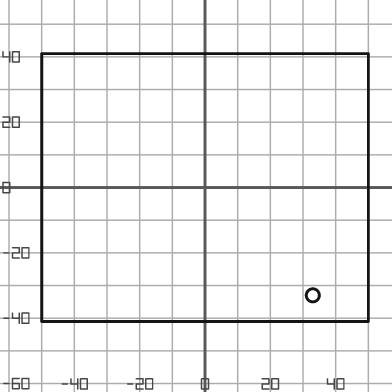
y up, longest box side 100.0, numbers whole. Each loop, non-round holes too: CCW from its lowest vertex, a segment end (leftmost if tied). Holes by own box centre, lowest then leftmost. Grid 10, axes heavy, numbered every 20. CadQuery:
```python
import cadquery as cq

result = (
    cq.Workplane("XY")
    .moveTo(-50.0, -41.0)
    .lineTo(50.0, -41.0)
    .lineTo(50.0, 41.0)
    .lineTo(-50.0, 41.0)
    .close()
    .moveTo(33.0, -33.0)
    .circle(2.0)
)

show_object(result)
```